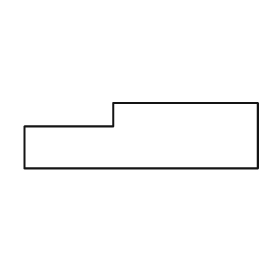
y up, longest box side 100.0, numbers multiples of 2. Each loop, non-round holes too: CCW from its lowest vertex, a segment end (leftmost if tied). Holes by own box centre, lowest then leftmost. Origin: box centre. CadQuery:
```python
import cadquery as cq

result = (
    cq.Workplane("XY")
    .moveTo(-50.0, -14.0)
    .lineTo(50.0, -14.0)
    .lineTo(50.0, 14.0)
    .lineTo(-12.0, 14.0)
    .lineTo(-12.0, 4.0)
    .lineTo(-50.0, 4.0)
    .close()
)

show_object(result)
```